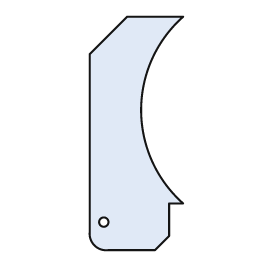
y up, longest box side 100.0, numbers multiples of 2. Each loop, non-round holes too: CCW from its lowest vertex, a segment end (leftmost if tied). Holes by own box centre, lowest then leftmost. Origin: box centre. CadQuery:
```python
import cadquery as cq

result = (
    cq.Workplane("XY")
    .moveTo(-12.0, -50.0)
    .lineTo(8.0, -50.0)
    .lineTo(14.0, -44.0)
    .lineTo(14.0, -30.0)
    .lineTo(20.0, -30.0)
    .threePointArc((2.0, 10.0), (20.0, 50.0))
    .lineTo(-4.0, 50.0)
    .lineTo(-20.0, 34.0)
    .lineTo(-20.0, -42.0)
    .threePointArc((-18.0, -48.0), (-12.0, -50.0))
    .close()
    .moveTo(-14.0, -38.0)
    .circle(2.0)
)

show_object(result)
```